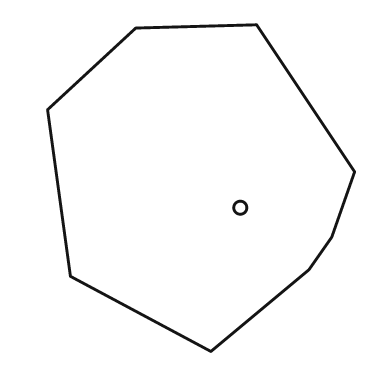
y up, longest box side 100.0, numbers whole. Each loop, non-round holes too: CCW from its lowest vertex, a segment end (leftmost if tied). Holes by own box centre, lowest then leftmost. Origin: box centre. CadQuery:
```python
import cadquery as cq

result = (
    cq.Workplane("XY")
    .moveTo(3.0, -50.0)
    .lineTo(33.0, -25.0)
    .lineTo(40.0, -15.0)
    .lineTo(47.0, 5.0)
    .lineTo(17.0, 50.0)
    .lineTo(-20.0, 49.0)
    .lineTo(-47.0, 24.0)
    .lineTo(-40.0, -27.0)
    .close()
    .moveTo(12.0, -6.0)
    .circle(2.0)
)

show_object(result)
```